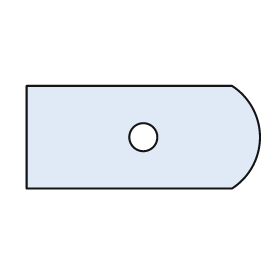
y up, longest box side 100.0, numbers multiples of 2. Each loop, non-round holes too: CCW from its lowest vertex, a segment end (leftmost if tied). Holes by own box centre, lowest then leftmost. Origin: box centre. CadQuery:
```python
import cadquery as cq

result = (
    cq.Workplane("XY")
    .moveTo(-50.0, -22.0)
    .lineTo(38.0, -22.0)
    .threePointArc((50.0, 0.0), (38.0, 22.0))
    .lineTo(-50.0, 22.0)
    .close()
    .moveTo(0.0, 0.0)
    .circle(6.0)
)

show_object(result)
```